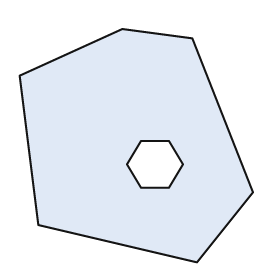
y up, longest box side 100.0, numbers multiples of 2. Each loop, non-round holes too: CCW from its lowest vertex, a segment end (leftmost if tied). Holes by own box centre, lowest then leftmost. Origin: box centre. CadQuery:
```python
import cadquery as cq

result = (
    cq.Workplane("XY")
    .moveTo(26.0, -50.0)
    .lineTo(50.0, -20.0)
    .lineTo(24.0, 46.0)
    .lineTo(-6.0, 50.0)
    .lineTo(-50.0, 30.0)
    .lineTo(-42.0, -34.0)
    .close()
    .moveTo(2.0, -18.0)
    .lineTo(14.0, -18.0)
    .lineTo(20.0, -8.0)
    .lineTo(14.0, 2.0)
    .lineTo(2.0, 2.0)
    .lineTo(-4.0, -8.0)
    .close()
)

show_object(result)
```